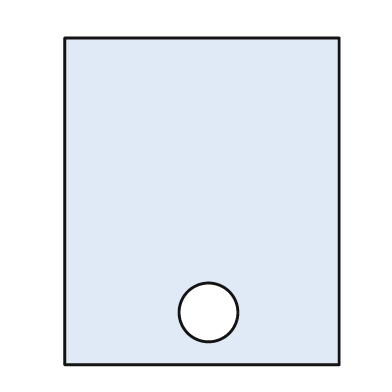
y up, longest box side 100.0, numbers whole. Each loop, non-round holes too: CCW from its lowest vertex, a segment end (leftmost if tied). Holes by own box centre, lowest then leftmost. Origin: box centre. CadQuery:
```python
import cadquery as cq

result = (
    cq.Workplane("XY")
    .moveTo(-42.0, -50.0)
    .lineTo(42.0, -50.0)
    .lineTo(42.0, 50.0)
    .lineTo(-42.0, 50.0)
    .close()
    .moveTo(2.0, -34.0)
    .circle(9.0)
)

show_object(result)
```